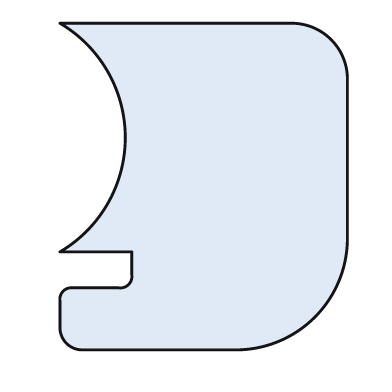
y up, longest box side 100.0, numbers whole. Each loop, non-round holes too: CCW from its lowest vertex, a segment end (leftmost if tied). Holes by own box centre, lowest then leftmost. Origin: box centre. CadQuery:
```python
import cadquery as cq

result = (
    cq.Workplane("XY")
    .moveTo(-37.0, -50.0)
    .lineTo(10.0, -50.0)
    .threePointArc((34.0, -40.0), (44.0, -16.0))
    .lineTo(44.0, 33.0)
    .threePointArc((39.0, 45.0), (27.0, 50.0))
    .lineTo(-44.0, 50.0)
    .threePointArc((-24.0, 15.0), (-44.0, -20.0))
    .lineTo(-22.0, -20.0)
    .lineTo(-22.0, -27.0)
    .threePointArc((-23.0, -30.0), (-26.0, -31.0))
    .lineTo(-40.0, -31.0)
    .threePointArc((-43.0, -32.0), (-44.0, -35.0))
    .lineTo(-44.0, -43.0)
    .threePointArc((-42.0, -48.0), (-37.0, -50.0))
    .close()
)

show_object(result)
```